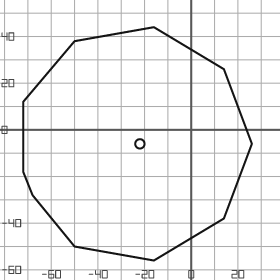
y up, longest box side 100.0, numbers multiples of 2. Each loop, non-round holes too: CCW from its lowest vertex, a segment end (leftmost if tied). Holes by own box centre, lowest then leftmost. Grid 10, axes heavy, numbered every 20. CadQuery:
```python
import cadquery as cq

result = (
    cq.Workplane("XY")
    .moveTo(-16.0, -56.0)
    .lineTo(14.0, -38.0)
    .lineTo(26.0, -6.0)
    .lineTo(14.0, 26.0)
    .lineTo(-16.0, 44.0)
    .lineTo(-50.0, 38.0)
    .lineTo(-72.0, 12.0)
    .lineTo(-72.0, -18.0)
    .lineTo(-68.0, -28.0)
    .lineTo(-50.0, -50.0)
    .close()
    .moveTo(-22.0, -6.0)
    .circle(2.0)
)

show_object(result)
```